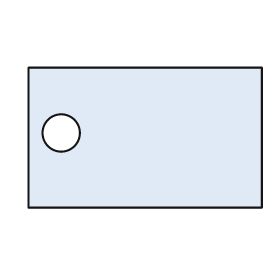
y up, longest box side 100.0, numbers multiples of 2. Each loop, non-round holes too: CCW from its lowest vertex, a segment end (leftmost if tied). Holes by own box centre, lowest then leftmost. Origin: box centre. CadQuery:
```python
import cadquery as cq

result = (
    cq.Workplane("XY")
    .moveTo(-50.0, -30.0)
    .lineTo(50.0, -30.0)
    .lineTo(50.0, 30.0)
    .lineTo(-50.0, 30.0)
    .close()
    .moveTo(-36.0, 2.0)
    .circle(8.0)
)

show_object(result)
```